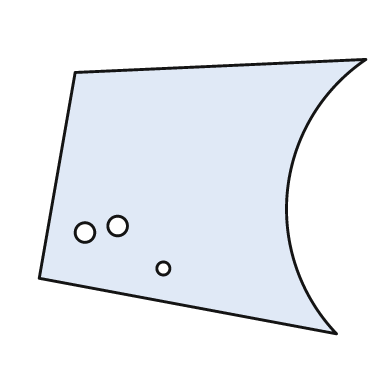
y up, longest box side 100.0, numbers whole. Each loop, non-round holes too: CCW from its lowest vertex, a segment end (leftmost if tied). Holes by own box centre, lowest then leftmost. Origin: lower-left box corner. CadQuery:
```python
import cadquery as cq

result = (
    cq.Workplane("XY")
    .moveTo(91.0, 0.0)
    .threePointArc((76.0, 44.0), (100.0, 84.0))
    .lineTo(11.0, 80.0)
    .lineTo(0.0, 17.0)
    .close()
    .moveTo(38.0, 20.0)
    .circle(2.0)
    .moveTo(14.0, 31.0)
    .circle(3.0)
    .moveTo(24.0, 33.0)
    .circle(3.0)
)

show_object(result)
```